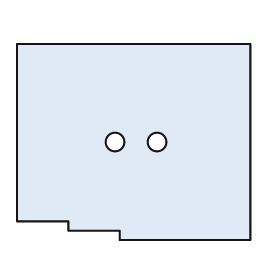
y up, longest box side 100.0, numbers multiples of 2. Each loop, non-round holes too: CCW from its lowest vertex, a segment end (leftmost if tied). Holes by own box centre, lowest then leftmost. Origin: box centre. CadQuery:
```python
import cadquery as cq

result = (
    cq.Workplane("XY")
    .moveTo(-6.0, -42.0)
    .lineTo(50.0, -42.0)
    .lineTo(50.0, 42.0)
    .lineTo(-50.0, 42.0)
    .lineTo(-50.0, -34.0)
    .lineTo(-28.0, -34.0)
    .lineTo(-28.0, -38.0)
    .lineTo(-6.0, -38.0)
    .close()
    .moveTo(-8.0, 0.0)
    .circle(4.0)
    .moveTo(10.0, 0.0)
    .circle(4.0)
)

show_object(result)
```